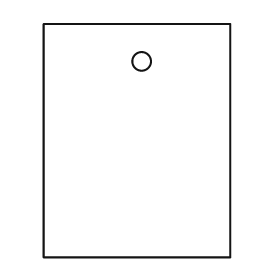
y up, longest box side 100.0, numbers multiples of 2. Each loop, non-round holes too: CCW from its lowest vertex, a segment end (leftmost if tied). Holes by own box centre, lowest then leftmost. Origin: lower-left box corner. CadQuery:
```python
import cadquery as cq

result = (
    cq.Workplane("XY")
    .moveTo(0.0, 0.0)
    .lineTo(80.0, 0.0)
    .lineTo(80.0, 100.0)
    .lineTo(0.0, 100.0)
    .close()
    .moveTo(42.0, 84.0)
    .circle(4.0)
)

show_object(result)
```